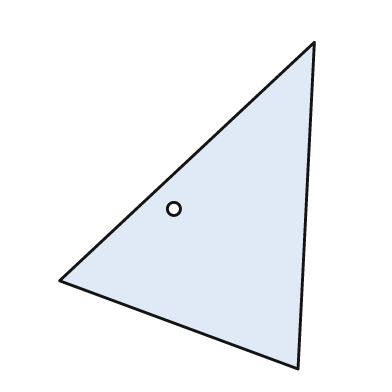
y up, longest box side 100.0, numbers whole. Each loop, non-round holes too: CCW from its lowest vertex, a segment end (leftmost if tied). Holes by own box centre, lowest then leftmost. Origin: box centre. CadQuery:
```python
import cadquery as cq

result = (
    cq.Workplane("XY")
    .moveTo(34.0, -50.0)
    .lineTo(39.0, 50.0)
    .lineTo(-39.0, -23.0)
    .close()
    .moveTo(-4.0, -1.0)
    .circle(2.0)
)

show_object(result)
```